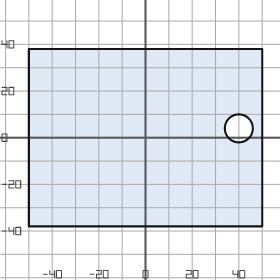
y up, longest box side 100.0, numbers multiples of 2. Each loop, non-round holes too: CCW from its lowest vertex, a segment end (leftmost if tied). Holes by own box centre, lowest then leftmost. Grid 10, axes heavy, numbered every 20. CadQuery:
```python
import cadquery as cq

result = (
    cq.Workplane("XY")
    .moveTo(-50.0, -38.0)
    .lineTo(50.0, -38.0)
    .lineTo(50.0, 38.0)
    .lineTo(-50.0, 38.0)
    .close()
    .moveTo(40.0, 4.0)
    .circle(6.0)
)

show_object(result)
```